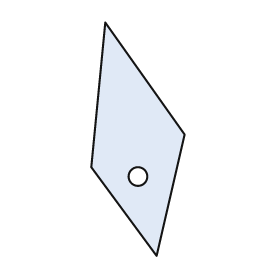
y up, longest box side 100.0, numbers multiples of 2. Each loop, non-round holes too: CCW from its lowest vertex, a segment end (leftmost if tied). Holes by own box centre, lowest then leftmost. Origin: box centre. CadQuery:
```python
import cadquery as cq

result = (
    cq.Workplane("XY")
    .moveTo(8.0, -50.0)
    .lineTo(20.0, 2.0)
    .lineTo(-14.0, 50.0)
    .lineTo(-20.0, -12.0)
    .close()
    .moveTo(0.0, -16.0)
    .circle(4.0)
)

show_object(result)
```